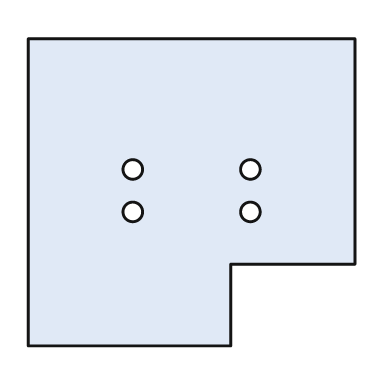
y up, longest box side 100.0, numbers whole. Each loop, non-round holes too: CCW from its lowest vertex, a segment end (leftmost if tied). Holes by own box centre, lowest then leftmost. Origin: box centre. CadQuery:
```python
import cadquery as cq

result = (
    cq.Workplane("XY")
    .moveTo(-50.0, -47.0)
    .lineTo(12.0, -47.0)
    .lineTo(12.0, -22.0)
    .lineTo(50.0, -22.0)
    .lineTo(50.0, 47.0)
    .lineTo(-50.0, 47.0)
    .close()
    .moveTo(-18.0, -6.0)
    .circle(3.0)
    .moveTo(18.0, -6.0)
    .circle(3.0)
    .moveTo(-18.0, 7.0)
    .circle(3.0)
    .moveTo(18.0, 7.0)
    .circle(3.0)
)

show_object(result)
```